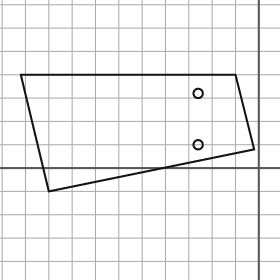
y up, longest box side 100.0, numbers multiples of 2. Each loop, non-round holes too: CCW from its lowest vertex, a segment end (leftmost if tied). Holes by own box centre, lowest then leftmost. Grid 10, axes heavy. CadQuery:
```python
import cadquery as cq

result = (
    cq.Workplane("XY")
    .moveTo(-90.0, -10.0)
    .lineTo(-2.0, 8.0)
    .lineTo(-10.0, 40.0)
    .lineTo(-102.0, 40.0)
    .close()
    .moveTo(-26.0, 10.0)
    .circle(2.0)
    .moveTo(-26.0, 32.0)
    .circle(2.0)
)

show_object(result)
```